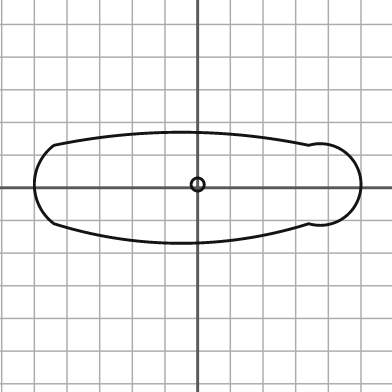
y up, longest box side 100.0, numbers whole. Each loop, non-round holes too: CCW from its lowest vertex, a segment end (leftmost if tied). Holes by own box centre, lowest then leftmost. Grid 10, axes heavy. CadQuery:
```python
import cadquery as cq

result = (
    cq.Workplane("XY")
    .moveTo(-44.0, -11.0)
    .threePointArc((-5.0, -17.0), (34.0, -11.0))
    .threePointArc((50.0, 1.0), (34.0, 13.0))
    .threePointArc((-5.0, 17.0), (-44.0, 13.0))
    .threePointArc((-50.0, 1.0), (-44.0, -11.0))
    .close()
    .moveTo(0.0, 1.0)
    .circle(2.0)
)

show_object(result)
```